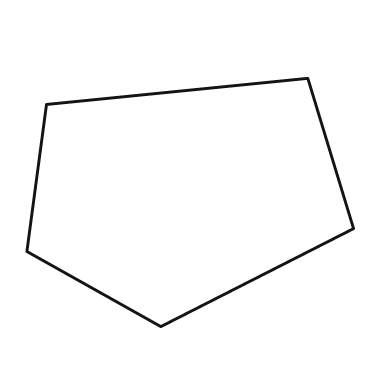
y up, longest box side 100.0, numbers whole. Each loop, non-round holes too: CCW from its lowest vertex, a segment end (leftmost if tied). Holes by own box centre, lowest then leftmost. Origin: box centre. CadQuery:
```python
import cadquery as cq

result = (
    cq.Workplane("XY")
    .moveTo(-9.0, -38.0)
    .lineTo(50.0, -8.0)
    .lineTo(36.0, 38.0)
    .lineTo(-44.0, 30.0)
    .lineTo(-50.0, -15.0)
    .close()
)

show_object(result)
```